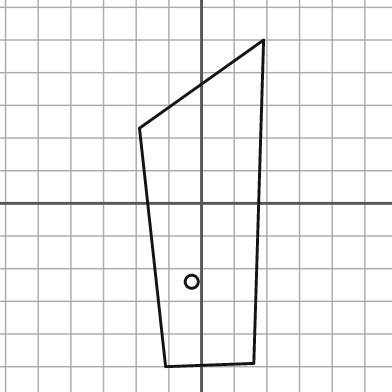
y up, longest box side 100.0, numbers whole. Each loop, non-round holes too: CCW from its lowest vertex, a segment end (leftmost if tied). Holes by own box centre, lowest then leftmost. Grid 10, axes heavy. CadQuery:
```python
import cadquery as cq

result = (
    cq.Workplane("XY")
    .moveTo(-11.0, -50.0)
    .lineTo(16.0, -49.0)
    .lineTo(19.0, 50.0)
    .lineTo(-19.0, 23.0)
    .close()
    .moveTo(-3.0, -24.0)
    .circle(2.0)
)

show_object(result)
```